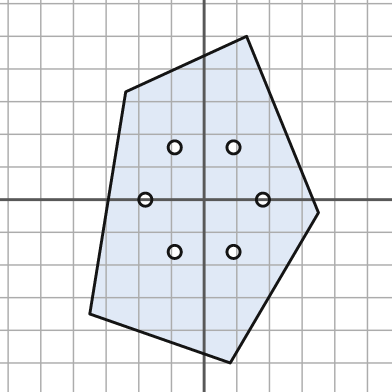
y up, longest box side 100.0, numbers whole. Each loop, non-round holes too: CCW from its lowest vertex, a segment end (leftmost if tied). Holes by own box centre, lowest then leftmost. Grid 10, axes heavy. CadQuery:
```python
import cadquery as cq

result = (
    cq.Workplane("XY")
    .moveTo(8.0, -50.0)
    .lineTo(35.0, -4.0)
    .lineTo(13.0, 50.0)
    .lineTo(-24.0, 33.0)
    .lineTo(-35.0, -35.0)
    .close()
    .moveTo(-9.0, -16.0)
    .circle(2.0)
    .moveTo(9.0, -16.0)
    .circle(2.0)
    .moveTo(-18.0, 0.0)
    .circle(2.0)
    .moveTo(18.0, 0.0)
    .circle(2.0)
    .moveTo(-9.0, 16.0)
    .circle(2.0)
    .moveTo(9.0, 16.0)
    .circle(2.0)
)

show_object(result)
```